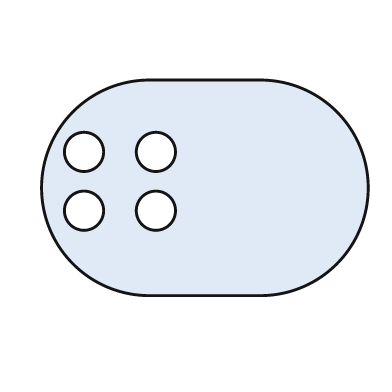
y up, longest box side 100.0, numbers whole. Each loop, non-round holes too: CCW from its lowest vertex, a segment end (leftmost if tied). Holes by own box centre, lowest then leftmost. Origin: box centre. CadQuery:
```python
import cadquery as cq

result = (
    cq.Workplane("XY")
    .moveTo(-17.0, -33.0)
    .lineTo(17.0, -33.0)
    .threePointArc((50.0, 0.0), (17.0, 33.0))
    .lineTo(-17.0, 33.0)
    .threePointArc((-50.0, 0.0), (-17.0, -33.0))
    .close()
    .moveTo(-37.0, -7.0)
    .circle(6.0)
    .moveTo(-15.0, -7.0)
    .circle(6.0)
    .moveTo(-37.0, 11.0)
    .circle(6.0)
    .moveTo(-15.0, 11.0)
    .circle(6.0)
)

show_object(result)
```